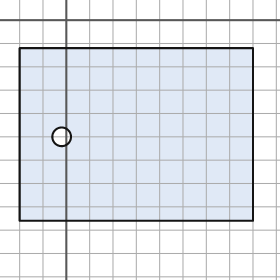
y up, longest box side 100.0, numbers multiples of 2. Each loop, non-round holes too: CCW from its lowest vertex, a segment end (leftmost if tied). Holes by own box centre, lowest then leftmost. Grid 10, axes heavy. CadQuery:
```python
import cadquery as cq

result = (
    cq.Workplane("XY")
    .moveTo(-20.0, -86.0)
    .lineTo(80.0, -86.0)
    .lineTo(80.0, -12.0)
    .lineTo(-20.0, -12.0)
    .close()
    .moveTo(-2.0, -50.0)
    .circle(4.0)
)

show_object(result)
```